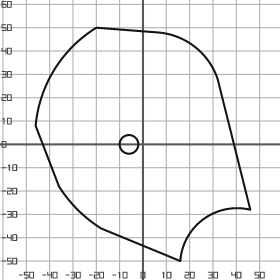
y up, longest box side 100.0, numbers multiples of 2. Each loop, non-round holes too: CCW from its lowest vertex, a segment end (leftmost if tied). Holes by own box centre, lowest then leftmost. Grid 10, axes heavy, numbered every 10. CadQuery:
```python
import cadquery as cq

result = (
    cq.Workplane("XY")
    .moveTo(16.0, -50.0)
    .threePointArc((26.0, -32.0), (46.0, -28.0))
    .lineTo(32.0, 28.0)
    .threePointArc((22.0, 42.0), (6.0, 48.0))
    .lineTo(-20.0, 50.0)
    .threePointArc((-38.0, 32.0), (-46.0, 8.0))
    .lineTo(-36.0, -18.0)
    .threePointArc((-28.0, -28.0), (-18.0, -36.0))
    .close()
    .moveTo(-6.0, 0.0)
    .circle(4.0)
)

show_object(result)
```